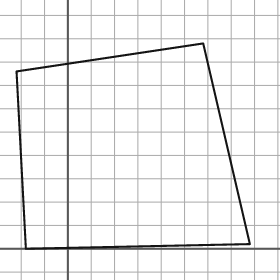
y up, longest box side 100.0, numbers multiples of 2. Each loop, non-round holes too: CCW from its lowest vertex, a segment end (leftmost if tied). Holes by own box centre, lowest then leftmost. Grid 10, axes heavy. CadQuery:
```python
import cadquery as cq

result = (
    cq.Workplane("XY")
    .moveTo(-18.0, 0.0)
    .lineTo(78.0, 2.0)
    .lineTo(58.0, 88.0)
    .lineTo(-22.0, 76.0)
    .close()
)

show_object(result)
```